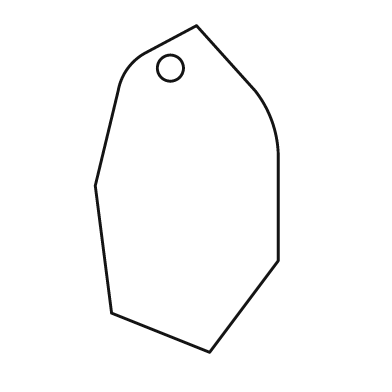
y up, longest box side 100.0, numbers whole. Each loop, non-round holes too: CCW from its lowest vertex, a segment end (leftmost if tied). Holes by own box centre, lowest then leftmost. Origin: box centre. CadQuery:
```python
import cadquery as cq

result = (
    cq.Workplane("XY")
    .moveTo(7.0, -50.0)
    .lineTo(28.0, -22.0)
    .lineTo(28.0, 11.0)
    .threePointArc((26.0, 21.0), (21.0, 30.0))
    .lineTo(3.0, 50.0)
    .lineTo(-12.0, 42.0)
    .threePointArc((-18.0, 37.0), (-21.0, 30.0))
    .lineTo(-28.0, 1.0)
    .lineTo(-23.0, -38.0)
    .close()
    .moveTo(-5.0, 37.0)
    .circle(4.0)
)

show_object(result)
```